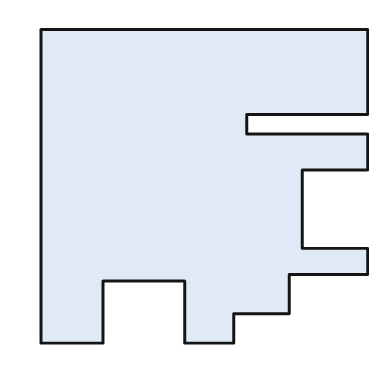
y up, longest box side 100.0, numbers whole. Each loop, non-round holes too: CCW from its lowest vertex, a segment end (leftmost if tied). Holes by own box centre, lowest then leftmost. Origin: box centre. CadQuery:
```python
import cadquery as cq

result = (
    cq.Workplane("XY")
    .moveTo(-50.0, -48.0)
    .lineTo(-31.0, -48.0)
    .lineTo(-31.0, -29.0)
    .lineTo(-6.0, -29.0)
    .lineTo(-6.0, -48.0)
    .lineTo(9.0, -48.0)
    .lineTo(9.0, -39.0)
    .lineTo(26.0, -39.0)
    .lineTo(26.0, -27.0)
    .lineTo(50.0, -27.0)
    .lineTo(50.0, -19.0)
    .lineTo(30.0, -19.0)
    .lineTo(30.0, 5.0)
    .lineTo(50.0, 5.0)
    .lineTo(50.0, 16.0)
    .lineTo(13.0, 16.0)
    .lineTo(13.0, 22.0)
    .lineTo(50.0, 22.0)
    .lineTo(50.0, 48.0)
    .lineTo(-50.0, 48.0)
    .close()
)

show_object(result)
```